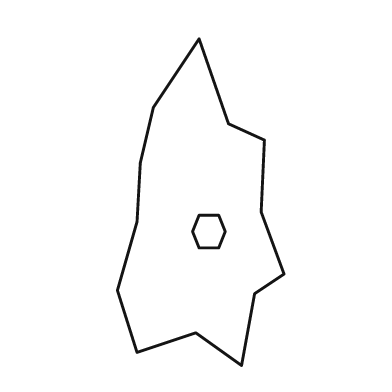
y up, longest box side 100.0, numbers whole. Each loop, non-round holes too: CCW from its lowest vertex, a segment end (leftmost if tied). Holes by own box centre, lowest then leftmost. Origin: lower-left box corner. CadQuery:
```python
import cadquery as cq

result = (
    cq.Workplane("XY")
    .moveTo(38.0, 0.0)
    .lineTo(42.0, 22.0)
    .lineTo(51.0, 28.0)
    .lineTo(44.0, 47.0)
    .lineTo(45.0, 69.0)
    .lineTo(34.0, 74.0)
    .lineTo(25.0, 100.0)
    .lineTo(11.0, 79.0)
    .lineTo(7.0, 62.0)
    .lineTo(6.0, 44.0)
    .lineTo(0.0, 23.0)
    .lineTo(6.0, 4.0)
    .lineTo(24.0, 10.0)
    .close()
    .moveTo(25.0, 36.0)
    .lineTo(31.0, 36.0)
    .lineTo(33.0, 41.0)
    .lineTo(31.0, 46.0)
    .lineTo(25.0, 46.0)
    .lineTo(23.0, 41.0)
    .close()
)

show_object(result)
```